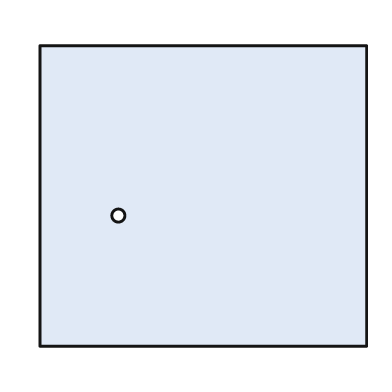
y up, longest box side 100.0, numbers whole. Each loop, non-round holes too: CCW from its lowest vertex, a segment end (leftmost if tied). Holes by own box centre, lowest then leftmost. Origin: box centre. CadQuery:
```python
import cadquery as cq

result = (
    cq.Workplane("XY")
    .moveTo(-50.0, -46.0)
    .lineTo(50.0, -46.0)
    .lineTo(50.0, 46.0)
    .lineTo(-50.0, 46.0)
    .close()
    .moveTo(-26.0, -6.0)
    .circle(2.0)
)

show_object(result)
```